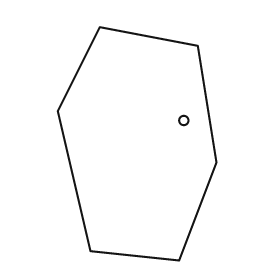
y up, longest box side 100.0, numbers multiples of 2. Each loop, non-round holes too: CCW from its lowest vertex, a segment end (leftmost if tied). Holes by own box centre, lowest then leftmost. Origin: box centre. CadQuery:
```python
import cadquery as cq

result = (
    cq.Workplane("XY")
    .moveTo(18.0, -50.0)
    .lineTo(34.0, -8.0)
    .lineTo(26.0, 42.0)
    .lineTo(-16.0, 50.0)
    .lineTo(-34.0, 14.0)
    .lineTo(-20.0, -46.0)
    .close()
    .moveTo(20.0, 10.0)
    .circle(2.0)
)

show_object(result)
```